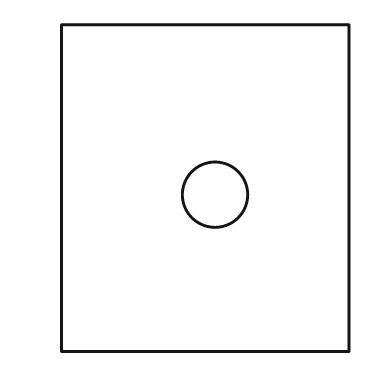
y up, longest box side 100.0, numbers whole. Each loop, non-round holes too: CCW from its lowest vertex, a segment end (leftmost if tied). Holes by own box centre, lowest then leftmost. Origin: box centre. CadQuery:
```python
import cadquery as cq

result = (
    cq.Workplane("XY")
    .moveTo(-44.0, -50.0)
    .lineTo(44.0, -50.0)
    .lineTo(44.0, 50.0)
    .lineTo(-44.0, 50.0)
    .close()
    .moveTo(3.0, -2.0)
    .circle(10.0)
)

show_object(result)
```